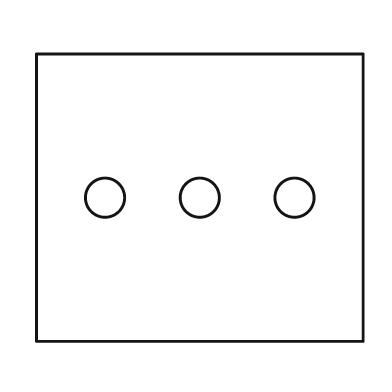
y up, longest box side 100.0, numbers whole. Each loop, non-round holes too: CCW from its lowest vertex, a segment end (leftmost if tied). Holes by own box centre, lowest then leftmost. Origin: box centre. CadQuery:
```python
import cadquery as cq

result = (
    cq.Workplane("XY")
    .moveTo(-50.0, -44.0)
    .lineTo(50.0, -44.0)
    .lineTo(50.0, 44.0)
    .lineTo(-50.0, 44.0)
    .close()
    .moveTo(-29.0, 0.0)
    .circle(6.0)
    .moveTo(0.0, 0.0)
    .circle(6.0)
    .moveTo(29.0, 0.0)
    .circle(6.0)
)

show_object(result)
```